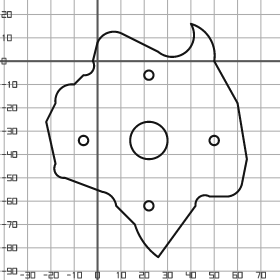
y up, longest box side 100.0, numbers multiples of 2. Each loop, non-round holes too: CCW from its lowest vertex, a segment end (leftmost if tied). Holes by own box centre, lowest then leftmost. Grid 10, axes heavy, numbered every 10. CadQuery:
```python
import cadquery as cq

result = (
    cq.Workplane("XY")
    .moveTo(26.0, -84.0)
    .lineTo(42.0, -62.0)
    .threePointArc((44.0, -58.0), (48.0, -58.0))
    .lineTo(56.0, -58.0)
    .threePointArc((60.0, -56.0), (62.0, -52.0))
    .lineTo(64.0, -42.0)
    .lineTo(60.0, -18.0)
    .lineTo(50.0, 0.0)
    .threePointArc((48.0, 10.0), (40.0, 16.0))
    .threePointArc((38.0, 4.0), (26.0, 4.0))
    .lineTo(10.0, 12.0)
    .threePointArc((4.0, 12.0), (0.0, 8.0))
    .lineTo(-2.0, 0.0)
    .threePointArc((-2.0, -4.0), (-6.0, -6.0))
    .lineTo(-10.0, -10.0)
    .threePointArc((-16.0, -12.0), (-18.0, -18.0))
    .lineTo(-22.0, -26.0)
    .lineTo(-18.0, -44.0)
    .threePointArc((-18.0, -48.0), (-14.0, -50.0))
    .lineTo(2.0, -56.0)
    .threePointArc((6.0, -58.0), (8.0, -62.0))
    .lineTo(16.0, -70.0)
    .threePointArc((20.0, -78.0), (26.0, -84.0))
    .close()
    .moveTo(22.0, -62.0)
    .circle(2.0)
    .moveTo(-6.0, -34.0)
    .circle(2.0)
    .moveTo(22.0, -34.0)
    .circle(8.0)
    .moveTo(50.0, -34.0)
    .circle(2.0)
    .moveTo(22.0, -6.0)
    .circle(2.0)
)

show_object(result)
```